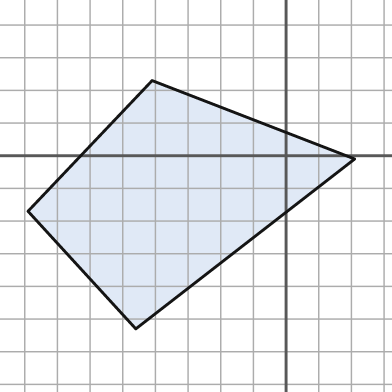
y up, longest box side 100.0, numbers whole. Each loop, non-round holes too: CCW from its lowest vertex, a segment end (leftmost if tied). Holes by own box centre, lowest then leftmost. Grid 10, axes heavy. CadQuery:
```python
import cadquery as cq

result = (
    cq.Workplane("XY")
    .moveTo(-46.0, -53.0)
    .lineTo(21.0, -1.0)
    .lineTo(-41.0, 23.0)
    .lineTo(-79.0, -17.0)
    .close()
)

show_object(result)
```